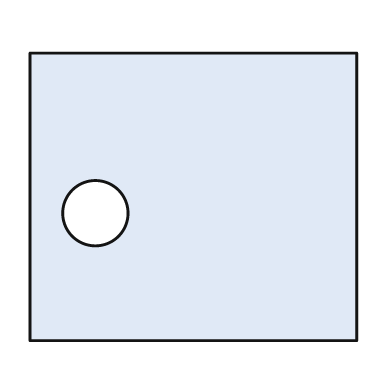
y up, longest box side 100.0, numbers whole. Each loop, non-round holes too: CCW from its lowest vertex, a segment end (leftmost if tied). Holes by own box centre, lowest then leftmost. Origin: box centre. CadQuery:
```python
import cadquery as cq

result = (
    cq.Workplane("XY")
    .moveTo(-50.0, -44.0)
    .lineTo(50.0, -44.0)
    .lineTo(50.0, 44.0)
    .lineTo(-50.0, 44.0)
    .close()
    .moveTo(-30.0, -5.0)
    .circle(10.0)
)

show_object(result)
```